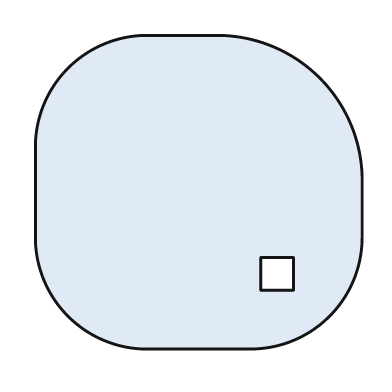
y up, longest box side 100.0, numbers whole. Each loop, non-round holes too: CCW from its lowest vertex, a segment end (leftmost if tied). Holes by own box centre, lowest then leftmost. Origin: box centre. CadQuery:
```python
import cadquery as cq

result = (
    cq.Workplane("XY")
    .moveTo(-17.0, -48.0)
    .lineTo(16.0, -48.0)
    .threePointArc((40.0, -38.0), (50.0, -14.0))
    .lineTo(50.0, 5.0)
    .threePointArc((37.0, 35.0), (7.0, 48.0))
    .lineTo(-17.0, 48.0)
    .threePointArc((-40.0, 38.0), (-50.0, 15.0))
    .lineTo(-50.0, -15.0)
    .threePointArc((-40.0, -38.0), (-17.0, -48.0))
    .close()
    .moveTo(19.0, -30.0)
    .lineTo(29.0, -30.0)
    .lineTo(29.0, -20.0)
    .lineTo(19.0, -20.0)
    .close()
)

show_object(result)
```